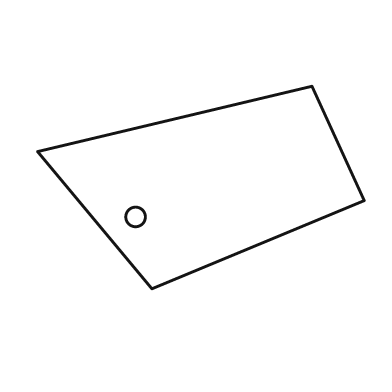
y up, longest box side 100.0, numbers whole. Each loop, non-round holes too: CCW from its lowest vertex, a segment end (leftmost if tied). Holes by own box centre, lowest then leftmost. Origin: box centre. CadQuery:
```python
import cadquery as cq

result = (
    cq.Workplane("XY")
    .moveTo(-15.0, -31.0)
    .lineTo(50.0, -4.0)
    .lineTo(34.0, 31.0)
    .lineTo(-50.0, 11.0)
    .close()
    .moveTo(-20.0, -9.0)
    .circle(3.0)
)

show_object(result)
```